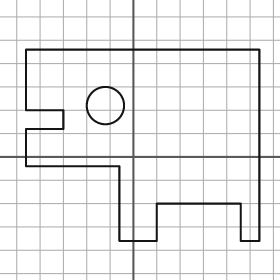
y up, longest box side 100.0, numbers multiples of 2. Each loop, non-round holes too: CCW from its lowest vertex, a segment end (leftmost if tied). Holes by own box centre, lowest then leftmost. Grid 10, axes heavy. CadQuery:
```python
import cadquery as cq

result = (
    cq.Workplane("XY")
    .moveTo(-6.0, -36.0)
    .lineTo(10.0, -36.0)
    .lineTo(10.0, -20.0)
    .lineTo(46.0, -20.0)
    .lineTo(46.0, -36.0)
    .lineTo(54.0, -36.0)
    .lineTo(54.0, 46.0)
    .lineTo(-46.0, 46.0)
    .lineTo(-46.0, 20.0)
    .lineTo(-30.0, 20.0)
    .lineTo(-30.0, 12.0)
    .lineTo(-46.0, 12.0)
    .lineTo(-46.0, -4.0)
    .lineTo(-6.0, -4.0)
    .close()
    .moveTo(-12.0, 22.0)
    .circle(8.0)
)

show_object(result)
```